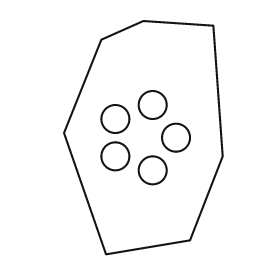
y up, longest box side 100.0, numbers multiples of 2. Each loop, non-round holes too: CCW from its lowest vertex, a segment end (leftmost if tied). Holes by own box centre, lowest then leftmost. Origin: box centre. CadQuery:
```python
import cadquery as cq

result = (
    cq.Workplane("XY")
    .moveTo(-16.0, -50.0)
    .lineTo(20.0, -44.0)
    .lineTo(34.0, -8.0)
    .lineTo(30.0, 48.0)
    .lineTo(0.0, 50.0)
    .lineTo(-18.0, 42.0)
    .lineTo(-34.0, 2.0)
    .close()
    .moveTo(4.0, -14.0)
    .circle(6.0)
    .moveTo(-12.0, -8.0)
    .circle(6.0)
    .moveTo(14.0, 0.0)
    .circle(6.0)
    .moveTo(-12.0, 8.0)
    .circle(6.0)
    .moveTo(4.0, 14.0)
    .circle(6.0)
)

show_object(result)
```